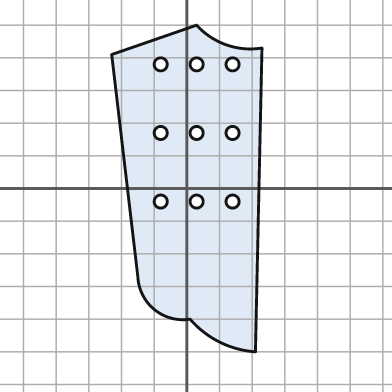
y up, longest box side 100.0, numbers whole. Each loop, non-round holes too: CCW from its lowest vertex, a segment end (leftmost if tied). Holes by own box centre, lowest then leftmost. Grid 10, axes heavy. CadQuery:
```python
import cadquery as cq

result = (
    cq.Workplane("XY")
    .moveTo(21.0, -50.0)
    .lineTo(23.0, 43.0)
    .threePointArc((12.0, 44.0), (3.0, 50.0))
    .lineTo(-23.0, 41.0)
    .lineTo(-15.0, -27.0)
    .threePointArc((-10.0, -37.0), (1.0, -40.0))
    .threePointArc((10.0, -47.0), (21.0, -50.0))
    .close()
    .moveTo(-8.0, -4.0)
    .circle(2.0)
    .moveTo(3.0, -4.0)
    .circle(2.0)
    .moveTo(14.0, -4.0)
    .circle(2.0)
    .moveTo(-8.0, 17.0)
    .circle(2.0)
    .moveTo(3.0, 17.0)
    .circle(2.0)
    .moveTo(14.0, 17.0)
    .circle(2.0)
    .moveTo(-8.0, 38.0)
    .circle(2.0)
    .moveTo(3.0, 38.0)
    .circle(2.0)
    .moveTo(14.0, 38.0)
    .circle(2.0)
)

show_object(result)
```